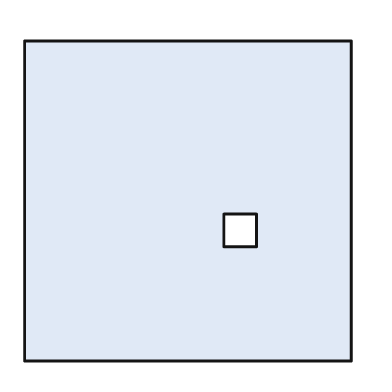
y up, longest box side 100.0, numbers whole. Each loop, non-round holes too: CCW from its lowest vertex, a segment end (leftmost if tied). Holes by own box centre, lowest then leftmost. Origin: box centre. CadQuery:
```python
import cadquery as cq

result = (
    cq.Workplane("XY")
    .moveTo(-50.0, -49.0)
    .lineTo(50.0, -49.0)
    .lineTo(50.0, 49.0)
    .lineTo(-50.0, 49.0)
    .close()
    .moveTo(11.0, -14.0)
    .lineTo(21.0, -14.0)
    .lineTo(21.0, -4.0)
    .lineTo(11.0, -4.0)
    .close()
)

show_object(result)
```